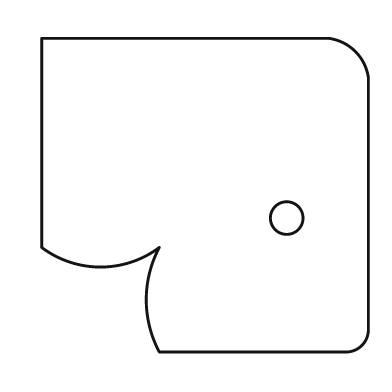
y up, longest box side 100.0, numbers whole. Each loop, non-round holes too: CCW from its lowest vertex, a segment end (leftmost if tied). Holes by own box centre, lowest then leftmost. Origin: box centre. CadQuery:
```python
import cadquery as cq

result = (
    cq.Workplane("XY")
    .moveTo(-14.0, -48.0)
    .lineTo(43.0, -48.0)
    .threePointArc((48.0, -46.0), (50.0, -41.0))
    .lineTo(50.0, 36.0)
    .threePointArc((46.0, 44.0), (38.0, 48.0))
    .lineTo(-50.0, 48.0)
    .lineTo(-50.0, -16.0)
    .threePointArc((-32.0, -22.0), (-14.0, -16.0))
    .threePointArc((-18.0, -32.0), (-14.0, -48.0))
    .close()
    .moveTo(25.0, -7.0)
    .circle(5.0)
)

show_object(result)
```